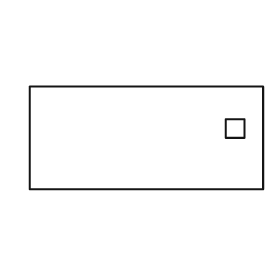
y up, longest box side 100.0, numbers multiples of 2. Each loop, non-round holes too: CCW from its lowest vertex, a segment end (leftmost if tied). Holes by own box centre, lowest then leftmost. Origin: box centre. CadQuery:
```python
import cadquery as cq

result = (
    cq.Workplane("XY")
    .moveTo(-50.0, -22.0)
    .lineTo(50.0, -22.0)
    .lineTo(50.0, 22.0)
    .lineTo(-50.0, 22.0)
    .close()
    .moveTo(34.0, 0.0)
    .lineTo(42.0, 0.0)
    .lineTo(42.0, 8.0)
    .lineTo(34.0, 8.0)
    .close()
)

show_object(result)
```